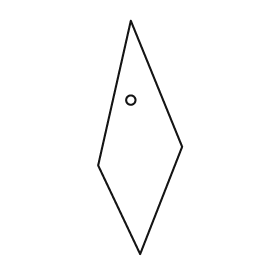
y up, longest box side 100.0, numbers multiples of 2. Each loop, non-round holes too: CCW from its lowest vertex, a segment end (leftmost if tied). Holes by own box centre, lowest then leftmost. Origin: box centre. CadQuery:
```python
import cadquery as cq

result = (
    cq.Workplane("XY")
    .moveTo(0.0, -50.0)
    .lineTo(18.0, -4.0)
    .lineTo(-4.0, 50.0)
    .lineTo(-18.0, -12.0)
    .close()
    .moveTo(-4.0, 16.0)
    .circle(2.0)
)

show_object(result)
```